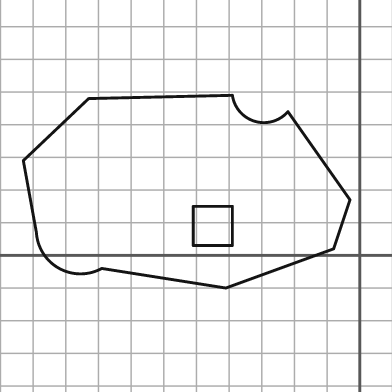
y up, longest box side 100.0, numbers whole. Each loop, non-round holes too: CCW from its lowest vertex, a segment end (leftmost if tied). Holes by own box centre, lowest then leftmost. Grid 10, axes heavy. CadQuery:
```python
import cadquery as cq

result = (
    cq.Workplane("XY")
    .moveTo(-41.0, -10.0)
    .lineTo(-8.0, 2.0)
    .lineTo(-3.0, 17.0)
    .lineTo(-22.0, 44.0)
    .threePointArc((-32.0, 41.0), (-39.0, 49.0))
    .lineTo(-83.0, 48.0)
    .lineTo(-103.0, 29.0)
    .lineTo(-99.0, 7.0)
    .threePointArc((-92.0, -4.0), (-79.0, -4.0))
    .close()
    .moveTo(-51.0, 3.0)
    .lineTo(-39.0, 3.0)
    .lineTo(-39.0, 15.0)
    .lineTo(-51.0, 15.0)
    .close()
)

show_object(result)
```